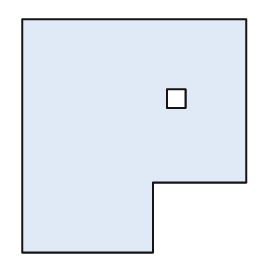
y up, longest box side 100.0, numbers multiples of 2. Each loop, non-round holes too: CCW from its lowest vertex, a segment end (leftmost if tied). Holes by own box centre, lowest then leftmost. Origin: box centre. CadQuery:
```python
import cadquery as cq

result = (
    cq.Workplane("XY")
    .moveTo(-48.0, -50.0)
    .lineTo(8.0, -50.0)
    .lineTo(8.0, -20.0)
    .lineTo(48.0, -20.0)
    .lineTo(48.0, 50.0)
    .lineTo(-48.0, 50.0)
    .close()
    .moveTo(14.0, 12.0)
    .lineTo(22.0, 12.0)
    .lineTo(22.0, 20.0)
    .lineTo(14.0, 20.0)
    .close()
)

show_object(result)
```